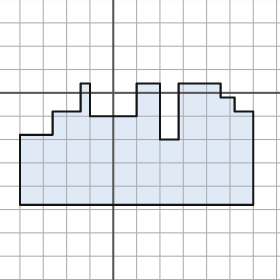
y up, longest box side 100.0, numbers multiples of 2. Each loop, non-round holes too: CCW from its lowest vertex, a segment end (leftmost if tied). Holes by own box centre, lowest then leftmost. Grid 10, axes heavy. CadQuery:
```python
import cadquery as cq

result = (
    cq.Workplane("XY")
    .moveTo(-40.0, -48.0)
    .lineTo(60.0, -48.0)
    .lineTo(60.0, -8.0)
    .lineTo(52.0, -8.0)
    .lineTo(52.0, -2.0)
    .lineTo(46.0, -2.0)
    .lineTo(46.0, 4.0)
    .lineTo(28.0, 4.0)
    .lineTo(28.0, -20.0)
    .lineTo(20.0, -20.0)
    .lineTo(20.0, 4.0)
    .lineTo(10.0, 4.0)
    .lineTo(10.0, -10.0)
    .lineTo(-10.0, -10.0)
    .lineTo(-10.0, 4.0)
    .lineTo(-14.0, 4.0)
    .lineTo(-14.0, -8.0)
    .lineTo(-26.0, -8.0)
    .lineTo(-26.0, -18.0)
    .lineTo(-40.0, -18.0)
    .close()
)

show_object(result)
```